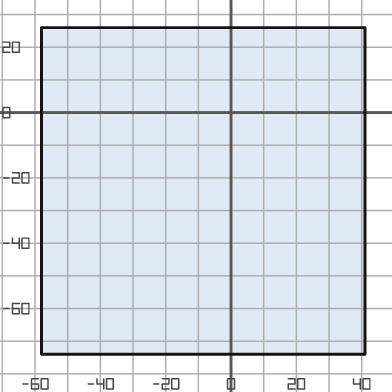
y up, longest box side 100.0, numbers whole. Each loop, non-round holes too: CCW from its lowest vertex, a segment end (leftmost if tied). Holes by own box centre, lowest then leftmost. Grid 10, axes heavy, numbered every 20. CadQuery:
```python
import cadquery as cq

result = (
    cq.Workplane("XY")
    .moveTo(-58.0, -74.0)
    .lineTo(41.0, -74.0)
    .lineTo(41.0, 26.0)
    .lineTo(-58.0, 26.0)
    .close()
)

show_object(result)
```